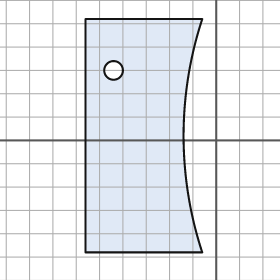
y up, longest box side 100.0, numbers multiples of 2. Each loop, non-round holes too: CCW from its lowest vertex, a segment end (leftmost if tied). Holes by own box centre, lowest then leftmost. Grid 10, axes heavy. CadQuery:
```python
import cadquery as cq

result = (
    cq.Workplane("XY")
    .moveTo(-56.0, -48.0)
    .lineTo(-6.0, -48.0)
    .threePointArc((-14.0, 2.0), (-6.0, 52.0))
    .lineTo(-56.0, 52.0)
    .close()
    .moveTo(-44.0, 30.0)
    .circle(4.0)
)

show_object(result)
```